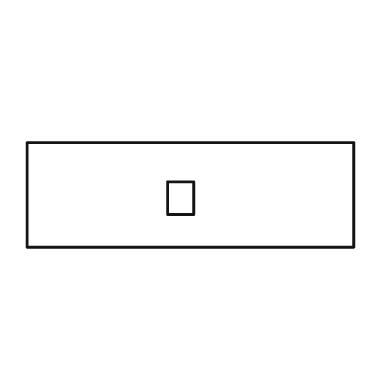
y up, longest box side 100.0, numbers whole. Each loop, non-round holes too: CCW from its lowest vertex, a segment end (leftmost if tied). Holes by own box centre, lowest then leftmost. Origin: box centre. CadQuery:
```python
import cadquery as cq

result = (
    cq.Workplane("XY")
    .moveTo(-50.0, -16.0)
    .lineTo(50.0, -16.0)
    .lineTo(50.0, 16.0)
    .lineTo(-50.0, 16.0)
    .close()
    .moveTo(-7.0, -6.0)
    .lineTo(1.0, -6.0)
    .lineTo(1.0, 4.0)
    .lineTo(-7.0, 4.0)
    .close()
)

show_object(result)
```